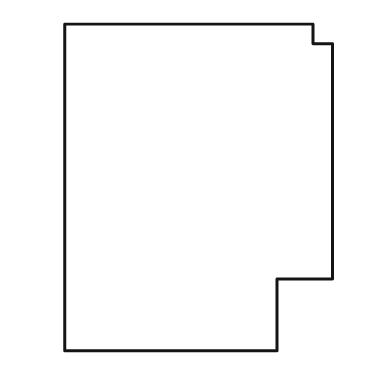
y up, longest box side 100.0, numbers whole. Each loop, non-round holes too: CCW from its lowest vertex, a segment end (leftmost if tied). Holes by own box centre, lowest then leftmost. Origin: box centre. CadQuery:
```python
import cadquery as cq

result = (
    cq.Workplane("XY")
    .moveTo(-41.0, -50.0)
    .lineTo(24.0, -50.0)
    .lineTo(24.0, -28.0)
    .lineTo(41.0, -28.0)
    .lineTo(41.0, 44.0)
    .lineTo(35.0, 44.0)
    .lineTo(35.0, 50.0)
    .lineTo(-41.0, 50.0)
    .close()
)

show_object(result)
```